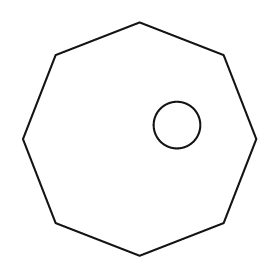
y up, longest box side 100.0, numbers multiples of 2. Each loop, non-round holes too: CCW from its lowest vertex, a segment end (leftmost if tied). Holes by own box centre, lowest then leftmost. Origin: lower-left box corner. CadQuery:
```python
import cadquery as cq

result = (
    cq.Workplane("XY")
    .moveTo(50.0, 0.0)
    .lineTo(86.0, 14.0)
    .lineTo(100.0, 50.0)
    .lineTo(86.0, 86.0)
    .lineTo(50.0, 100.0)
    .lineTo(14.0, 86.0)
    .lineTo(0.0, 50.0)
    .lineTo(14.0, 14.0)
    .close()
    .moveTo(66.0, 56.0)
    .circle(10.0)
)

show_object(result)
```